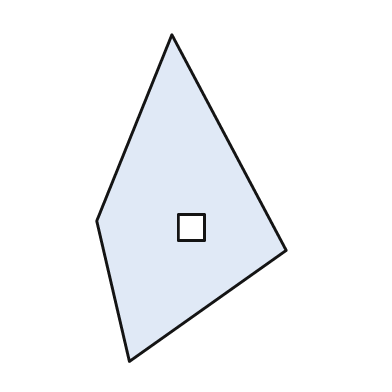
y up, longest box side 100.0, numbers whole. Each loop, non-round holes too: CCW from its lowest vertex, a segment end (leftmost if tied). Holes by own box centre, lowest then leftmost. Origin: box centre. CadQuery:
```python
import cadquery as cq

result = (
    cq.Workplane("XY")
    .moveTo(-19.0, -50.0)
    .lineTo(29.0, -16.0)
    .lineTo(-6.0, 50.0)
    .lineTo(-29.0, -7.0)
    .close()
    .moveTo(-4.0, -13.0)
    .lineTo(4.0, -13.0)
    .lineTo(4.0, -5.0)
    .lineTo(-4.0, -5.0)
    .close()
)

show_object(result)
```